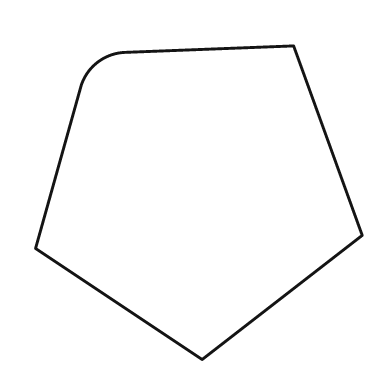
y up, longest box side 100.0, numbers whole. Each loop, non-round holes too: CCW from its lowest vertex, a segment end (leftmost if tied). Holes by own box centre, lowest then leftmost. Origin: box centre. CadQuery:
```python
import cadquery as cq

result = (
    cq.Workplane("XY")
    .moveTo(1.0, -48.0)
    .lineTo(50.0, -10.0)
    .lineTo(29.0, 48.0)
    .lineTo(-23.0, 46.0)
    .threePointArc((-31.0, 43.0), (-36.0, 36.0))
    .lineTo(-50.0, -14.0)
    .close()
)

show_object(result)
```